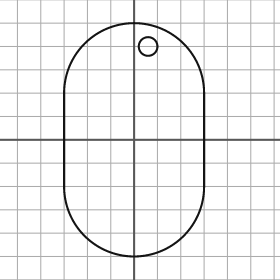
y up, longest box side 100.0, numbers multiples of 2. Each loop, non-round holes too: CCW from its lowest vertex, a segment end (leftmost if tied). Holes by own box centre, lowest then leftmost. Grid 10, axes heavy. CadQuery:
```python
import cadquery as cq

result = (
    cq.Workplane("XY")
    .moveTo(-30.0, -20.0)
    .threePointArc((0.0, -50.0), (30.0, -20.0))
    .lineTo(30.0, 20.0)
    .threePointArc((0.0, 50.0), (-30.0, 20.0))
    .close()
    .moveTo(6.0, 40.0)
    .circle(4.0)
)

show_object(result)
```